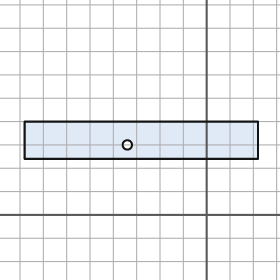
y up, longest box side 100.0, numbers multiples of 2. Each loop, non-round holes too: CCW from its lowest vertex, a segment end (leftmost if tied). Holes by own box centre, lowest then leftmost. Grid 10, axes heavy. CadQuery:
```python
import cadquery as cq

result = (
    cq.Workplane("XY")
    .moveTo(-78.0, 24.0)
    .lineTo(22.0, 24.0)
    .lineTo(22.0, 40.0)
    .lineTo(-78.0, 40.0)
    .close()
    .moveTo(-34.0, 30.0)
    .circle(2.0)
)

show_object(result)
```